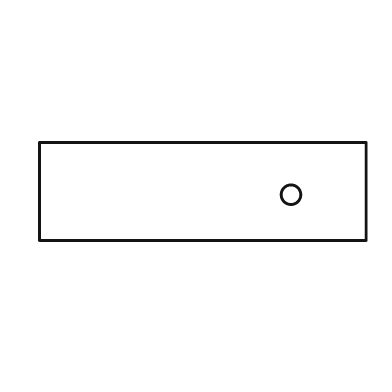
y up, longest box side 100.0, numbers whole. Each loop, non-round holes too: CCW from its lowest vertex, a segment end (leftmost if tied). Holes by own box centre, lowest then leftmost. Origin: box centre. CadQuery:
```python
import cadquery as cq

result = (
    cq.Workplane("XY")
    .moveTo(-50.0, -15.0)
    .lineTo(50.0, -15.0)
    .lineTo(50.0, 15.0)
    .lineTo(-50.0, 15.0)
    .close()
    .moveTo(27.0, -1.0)
    .circle(3.0)
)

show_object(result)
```